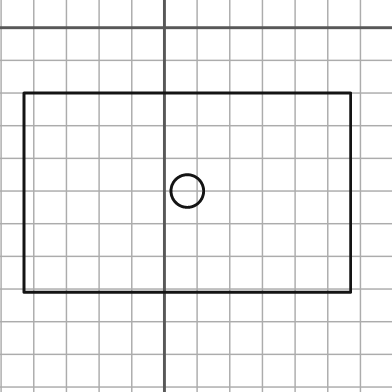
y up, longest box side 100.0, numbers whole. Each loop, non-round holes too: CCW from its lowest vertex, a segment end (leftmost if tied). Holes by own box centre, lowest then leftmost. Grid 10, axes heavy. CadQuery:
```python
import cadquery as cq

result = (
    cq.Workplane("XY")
    .moveTo(-43.0, -81.0)
    .lineTo(57.0, -81.0)
    .lineTo(57.0, -20.0)
    .lineTo(-43.0, -20.0)
    .close()
    .moveTo(7.0, -50.0)
    .circle(5.0)
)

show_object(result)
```